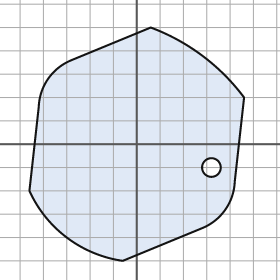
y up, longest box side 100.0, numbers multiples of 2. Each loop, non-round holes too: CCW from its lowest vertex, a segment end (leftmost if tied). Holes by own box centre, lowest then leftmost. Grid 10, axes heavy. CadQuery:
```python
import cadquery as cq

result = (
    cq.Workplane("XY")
    .moveTo(-6.0, -50.0)
    .lineTo(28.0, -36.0)
    .threePointArc((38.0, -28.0), (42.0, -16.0))
    .lineTo(46.0, 20.0)
    .threePointArc((28.0, 38.0), (6.0, 50.0))
    .lineTo(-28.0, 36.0)
    .threePointArc((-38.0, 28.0), (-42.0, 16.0))
    .lineTo(-46.0, -20.0)
    .threePointArc((-30.0, -40.0), (-6.0, -50.0))
    .close()
    .moveTo(32.0, -10.0)
    .circle(4.0)
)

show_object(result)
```